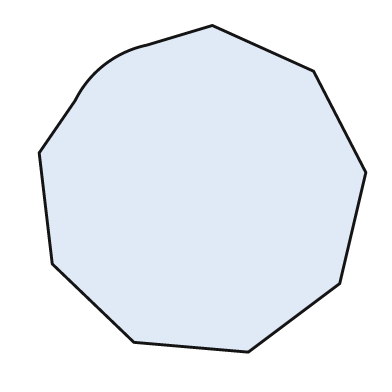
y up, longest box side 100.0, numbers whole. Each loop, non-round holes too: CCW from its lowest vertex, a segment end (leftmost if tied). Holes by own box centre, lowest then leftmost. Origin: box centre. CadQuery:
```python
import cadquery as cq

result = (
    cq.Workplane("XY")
    .moveTo(14.0, -50.0)
    .lineTo(42.0, -29.0)
    .lineTo(50.0, 5.0)
    .lineTo(34.0, 36.0)
    .lineTo(3.0, 50.0)
    .lineTo(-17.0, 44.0)
    .threePointArc((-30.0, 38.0), (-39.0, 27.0))
    .lineTo(-50.0, 11.0)
    .lineTo(-46.0, -23.0)
    .lineTo(-21.0, -47.0)
    .close()
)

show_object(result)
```